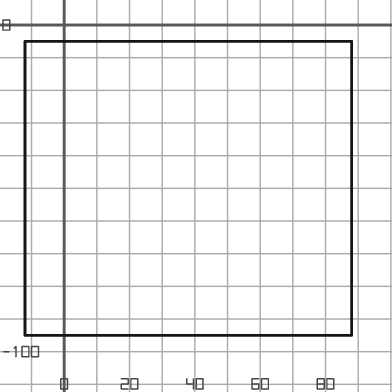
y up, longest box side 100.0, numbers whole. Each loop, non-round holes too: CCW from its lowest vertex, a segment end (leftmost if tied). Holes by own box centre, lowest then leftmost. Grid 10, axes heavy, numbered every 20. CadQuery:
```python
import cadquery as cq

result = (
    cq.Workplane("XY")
    .moveTo(-12.0, -95.0)
    .lineTo(88.0, -95.0)
    .lineTo(88.0, -5.0)
    .lineTo(-12.0, -5.0)
    .close()
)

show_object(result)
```